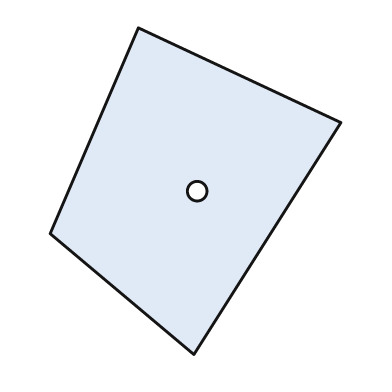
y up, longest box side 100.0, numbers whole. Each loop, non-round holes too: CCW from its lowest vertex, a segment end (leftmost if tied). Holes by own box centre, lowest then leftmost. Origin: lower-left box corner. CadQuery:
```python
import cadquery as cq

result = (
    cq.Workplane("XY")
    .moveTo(44.0, 0.0)
    .lineTo(89.0, 71.0)
    .lineTo(27.0, 100.0)
    .lineTo(0.0, 37.0)
    .close()
    .moveTo(45.0, 50.0)
    .circle(3.0)
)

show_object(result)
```